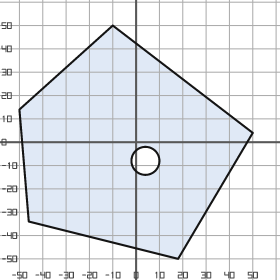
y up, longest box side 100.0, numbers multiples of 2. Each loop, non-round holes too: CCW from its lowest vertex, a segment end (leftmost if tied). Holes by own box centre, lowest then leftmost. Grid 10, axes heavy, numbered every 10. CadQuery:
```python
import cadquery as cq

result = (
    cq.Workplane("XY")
    .moveTo(18.0, -50.0)
    .lineTo(50.0, 4.0)
    .lineTo(-10.0, 50.0)
    .lineTo(-50.0, 14.0)
    .lineTo(-46.0, -34.0)
    .close()
    .moveTo(4.0, -8.0)
    .circle(6.0)
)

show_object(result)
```